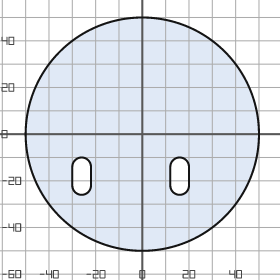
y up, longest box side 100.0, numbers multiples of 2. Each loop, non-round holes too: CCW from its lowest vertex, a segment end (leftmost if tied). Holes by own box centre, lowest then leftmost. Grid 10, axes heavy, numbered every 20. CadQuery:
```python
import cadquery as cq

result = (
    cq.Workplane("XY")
    .moveTo(0.0, 0.0)
    .circle(50.0)
    .moveTo(-30.0, -22.0)
    .threePointArc((-26.0, -26.0), (-22.0, -22.0))
    .lineTo(-22.0, -14.0)
    .threePointArc((-26.0, -10.0), (-30.0, -14.0))
    .close()
    .moveTo(12.0, -22.0)
    .threePointArc((16.0, -26.0), (20.0, -22.0))
    .lineTo(20.0, -14.0)
    .threePointArc((16.0, -10.0), (12.0, -14.0))
    .close()
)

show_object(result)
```